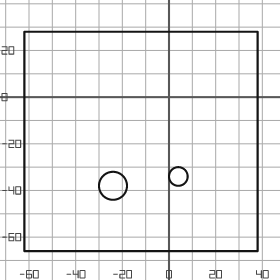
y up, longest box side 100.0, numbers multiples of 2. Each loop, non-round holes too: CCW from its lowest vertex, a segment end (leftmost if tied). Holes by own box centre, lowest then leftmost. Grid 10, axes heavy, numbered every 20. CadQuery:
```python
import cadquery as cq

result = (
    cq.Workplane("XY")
    .moveTo(-62.0, -66.0)
    .lineTo(38.0, -66.0)
    .lineTo(38.0, 28.0)
    .lineTo(-62.0, 28.0)
    .close()
    .moveTo(-24.0, -38.0)
    .circle(6.0)
    .moveTo(4.0, -34.0)
    .circle(4.0)
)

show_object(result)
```